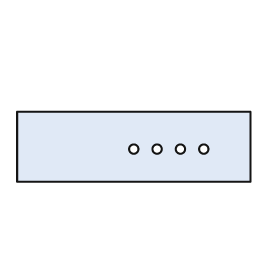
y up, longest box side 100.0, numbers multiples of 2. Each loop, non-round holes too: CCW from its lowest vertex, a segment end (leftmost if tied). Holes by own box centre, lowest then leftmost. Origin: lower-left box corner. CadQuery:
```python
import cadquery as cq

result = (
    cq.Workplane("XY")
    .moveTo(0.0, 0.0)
    .lineTo(100.0, 0.0)
    .lineTo(100.0, 30.0)
    .lineTo(0.0, 30.0)
    .close()
    .moveTo(50.0, 14.0)
    .circle(2.0)
    .moveTo(60.0, 14.0)
    .circle(2.0)
    .moveTo(70.0, 14.0)
    .circle(2.0)
    .moveTo(80.0, 14.0)
    .circle(2.0)
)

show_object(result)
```